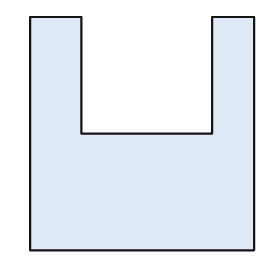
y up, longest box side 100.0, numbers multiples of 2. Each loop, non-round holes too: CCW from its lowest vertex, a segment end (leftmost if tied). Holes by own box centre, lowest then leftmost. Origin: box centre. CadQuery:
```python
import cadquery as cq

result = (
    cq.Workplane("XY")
    .moveTo(-48.0, -50.0)
    .lineTo(48.0, -50.0)
    .lineTo(48.0, 50.0)
    .lineTo(30.0, 50.0)
    .lineTo(30.0, 0.0)
    .lineTo(-26.0, 0.0)
    .lineTo(-26.0, 50.0)
    .lineTo(-48.0, 50.0)
    .close()
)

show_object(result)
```